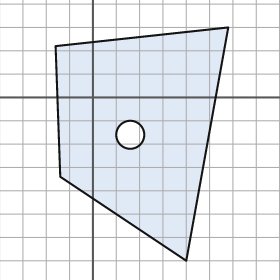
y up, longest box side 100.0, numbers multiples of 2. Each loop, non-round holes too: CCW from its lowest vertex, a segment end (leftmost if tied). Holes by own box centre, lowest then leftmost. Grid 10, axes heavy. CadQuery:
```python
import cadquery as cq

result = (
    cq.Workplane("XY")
    .moveTo(40.0, -70.0)
    .lineTo(58.0, 30.0)
    .lineTo(-16.0, 22.0)
    .lineTo(-14.0, -34.0)
    .close()
    .moveTo(16.0, -16.0)
    .circle(6.0)
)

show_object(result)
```